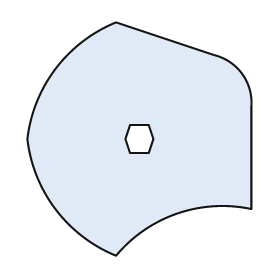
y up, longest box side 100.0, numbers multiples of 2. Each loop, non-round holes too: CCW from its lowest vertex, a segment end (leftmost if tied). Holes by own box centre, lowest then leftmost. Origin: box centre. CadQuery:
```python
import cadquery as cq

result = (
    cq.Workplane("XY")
    .moveTo(-10.0, -50.0)
    .threePointArc((16.0, -32.0), (48.0, -30.0))
    .lineTo(48.0, 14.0)
    .threePointArc((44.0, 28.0), (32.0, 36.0))
    .lineTo(-10.0, 50.0)
    .threePointArc((-36.0, 30.0), (-48.0, 0.0))
    .threePointArc((-36.0, -30.0), (-10.0, -50.0))
    .close()
    .moveTo(-4.0, -6.0)
    .lineTo(4.0, -6.0)
    .lineTo(6.0, 0.0)
    .lineTo(4.0, 6.0)
    .lineTo(-4.0, 6.0)
    .lineTo(-6.0, 0.0)
    .close()
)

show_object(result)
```